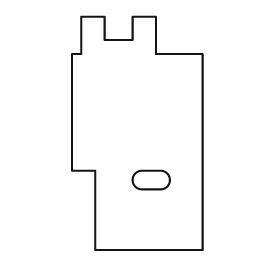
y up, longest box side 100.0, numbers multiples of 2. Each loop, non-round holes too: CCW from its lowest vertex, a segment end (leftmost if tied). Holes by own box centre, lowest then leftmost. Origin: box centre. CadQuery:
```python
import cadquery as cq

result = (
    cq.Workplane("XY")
    .moveTo(-18.0, -50.0)
    .lineTo(28.0, -50.0)
    .lineTo(28.0, 34.0)
    .lineTo(8.0, 34.0)
    .lineTo(8.0, 50.0)
    .lineTo(-2.0, 50.0)
    .lineTo(-2.0, 40.0)
    .lineTo(-14.0, 40.0)
    .lineTo(-14.0, 50.0)
    .lineTo(-24.0, 50.0)
    .lineTo(-24.0, 34.0)
    .lineTo(-28.0, 34.0)
    .lineTo(-28.0, -16.0)
    .lineTo(-18.0, -16.0)
    .close()
    .moveTo(2.0, -24.0)
    .lineTo(10.0, -24.0)
    .threePointArc((14.0, -20.0), (10.0, -16.0))
    .lineTo(2.0, -16.0)
    .threePointArc((-2.0, -20.0), (2.0, -24.0))
    .close()
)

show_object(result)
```